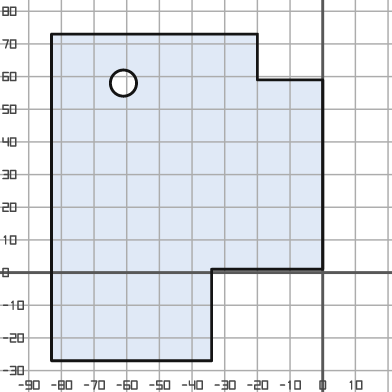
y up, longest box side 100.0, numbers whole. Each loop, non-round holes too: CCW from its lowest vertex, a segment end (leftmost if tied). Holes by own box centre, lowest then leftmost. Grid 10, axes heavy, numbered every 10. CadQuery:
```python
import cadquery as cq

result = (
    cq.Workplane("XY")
    .moveTo(-83.0, -27.0)
    .lineTo(-34.0, -27.0)
    .lineTo(-34.0, 1.0)
    .lineTo(0.0, 1.0)
    .lineTo(0.0, 59.0)
    .lineTo(-20.0, 59.0)
    .lineTo(-20.0, 73.0)
    .lineTo(-83.0, 73.0)
    .close()
    .moveTo(-61.0, 58.0)
    .circle(4.0)
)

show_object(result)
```